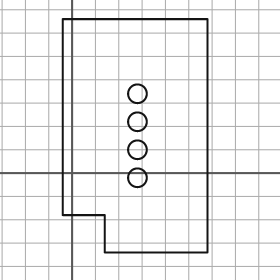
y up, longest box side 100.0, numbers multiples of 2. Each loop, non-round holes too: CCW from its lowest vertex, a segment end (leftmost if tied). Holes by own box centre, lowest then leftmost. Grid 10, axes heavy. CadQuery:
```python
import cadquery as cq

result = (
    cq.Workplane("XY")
    .moveTo(14.0, -34.0)
    .lineTo(58.0, -34.0)
    .lineTo(58.0, 66.0)
    .lineTo(-4.0, 66.0)
    .lineTo(-4.0, -18.0)
    .lineTo(14.0, -18.0)
    .close()
    .moveTo(28.0, -2.0)
    .circle(4.0)
    .moveTo(28.0, 10.0)
    .circle(4.0)
    .moveTo(28.0, 22.0)
    .circle(4.0)
    .moveTo(28.0, 34.0)
    .circle(4.0)
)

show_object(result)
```